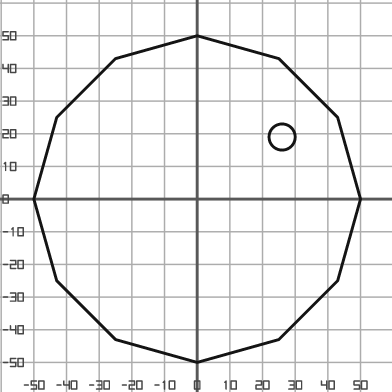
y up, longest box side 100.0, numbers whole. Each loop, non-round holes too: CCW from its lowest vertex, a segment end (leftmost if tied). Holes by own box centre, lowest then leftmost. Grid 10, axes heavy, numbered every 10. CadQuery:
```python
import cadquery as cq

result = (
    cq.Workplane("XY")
    .moveTo(0.0, -50.0)
    .lineTo(25.0, -43.0)
    .lineTo(43.0, -25.0)
    .lineTo(50.0, 0.0)
    .lineTo(43.0, 25.0)
    .lineTo(25.0, 43.0)
    .lineTo(0.0, 50.0)
    .lineTo(-25.0, 43.0)
    .lineTo(-43.0, 25.0)
    .lineTo(-50.0, 0.0)
    .lineTo(-43.0, -25.0)
    .lineTo(-25.0, -43.0)
    .close()
    .moveTo(26.0, 19.0)
    .circle(4.0)
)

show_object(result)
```